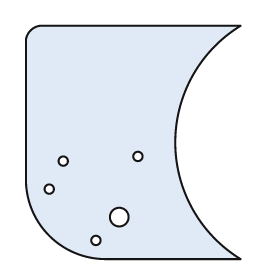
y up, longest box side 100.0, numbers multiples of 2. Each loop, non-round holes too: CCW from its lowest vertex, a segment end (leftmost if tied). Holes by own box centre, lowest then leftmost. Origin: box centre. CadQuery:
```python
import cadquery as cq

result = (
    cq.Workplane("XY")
    .moveTo(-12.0, -50.0)
    .lineTo(46.0, -50.0)
    .threePointArc((18.0, 0.0), (46.0, 50.0))
    .lineTo(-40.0, 50.0)
    .threePointArc((-44.0, 48.0), (-46.0, 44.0))
    .lineTo(-46.0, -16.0)
    .threePointArc((-36.0, -40.0), (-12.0, -50.0))
    .close()
    .moveTo(-16.0, -42.0)
    .circle(2.0)
    .moveTo(-6.0, -32.0)
    .circle(4.0)
    .moveTo(-36.0, -20.0)
    .circle(2.0)
    .moveTo(-30.0, -8.0)
    .circle(2.0)
    .moveTo(2.0, -6.0)
    .circle(2.0)
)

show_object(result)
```